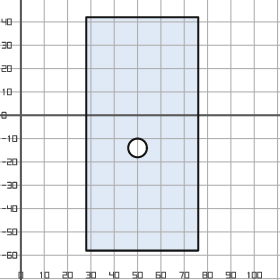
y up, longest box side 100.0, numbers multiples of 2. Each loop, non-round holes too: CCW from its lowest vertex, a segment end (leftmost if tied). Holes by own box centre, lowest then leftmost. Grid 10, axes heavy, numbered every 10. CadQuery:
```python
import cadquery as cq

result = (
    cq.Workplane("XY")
    .moveTo(28.0, -58.0)
    .lineTo(76.0, -58.0)
    .lineTo(76.0, 42.0)
    .lineTo(28.0, 42.0)
    .close()
    .moveTo(50.0, -14.0)
    .circle(4.0)
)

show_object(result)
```